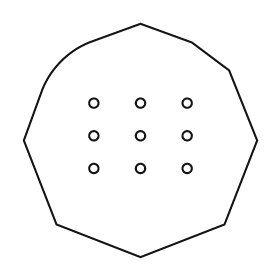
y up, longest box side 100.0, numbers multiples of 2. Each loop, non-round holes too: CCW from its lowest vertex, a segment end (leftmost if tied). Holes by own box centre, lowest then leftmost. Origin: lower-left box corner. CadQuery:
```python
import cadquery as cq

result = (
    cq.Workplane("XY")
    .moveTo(50.0, 0.0)
    .lineTo(86.0, 14.0)
    .lineTo(100.0, 50.0)
    .lineTo(88.0, 80.0)
    .lineTo(72.0, 92.0)
    .lineTo(50.0, 100.0)
    .lineTo(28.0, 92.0)
    .threePointArc((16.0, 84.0), (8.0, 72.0))
    .lineTo(0.0, 50.0)
    .lineTo(14.0, 14.0)
    .close()
    .moveTo(30.0, 38.0)
    .circle(2.0)
    .moveTo(50.0, 38.0)
    .circle(2.0)
    .moveTo(70.0, 38.0)
    .circle(2.0)
    .moveTo(30.0, 52.0)
    .circle(2.0)
    .moveTo(50.0, 52.0)
    .circle(2.0)
    .moveTo(70.0, 52.0)
    .circle(2.0)
    .moveTo(30.0, 66.0)
    .circle(2.0)
    .moveTo(50.0, 66.0)
    .circle(2.0)
    .moveTo(70.0, 66.0)
    .circle(2.0)
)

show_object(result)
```